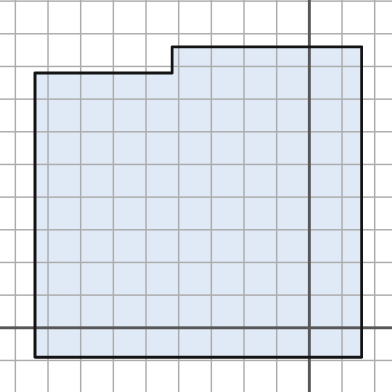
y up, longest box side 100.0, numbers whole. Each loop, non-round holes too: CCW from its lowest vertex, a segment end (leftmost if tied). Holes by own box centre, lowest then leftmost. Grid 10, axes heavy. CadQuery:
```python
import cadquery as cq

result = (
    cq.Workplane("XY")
    .moveTo(-84.0, -9.0)
    .lineTo(16.0, -9.0)
    .lineTo(16.0, 86.0)
    .lineTo(-42.0, 86.0)
    .lineTo(-42.0, 78.0)
    .lineTo(-84.0, 78.0)
    .close()
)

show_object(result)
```